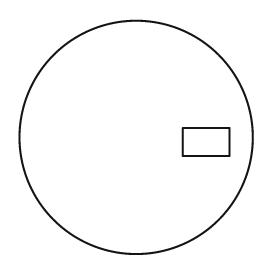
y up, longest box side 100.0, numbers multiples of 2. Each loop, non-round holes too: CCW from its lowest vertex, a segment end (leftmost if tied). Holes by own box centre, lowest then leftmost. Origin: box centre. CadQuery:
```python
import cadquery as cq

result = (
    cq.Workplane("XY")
    .moveTo(0.0, 0.0)
    .circle(50.0)
    .moveTo(20.0, -8.0)
    .lineTo(40.0, -8.0)
    .lineTo(40.0, 4.0)
    .lineTo(20.0, 4.0)
    .close()
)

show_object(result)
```